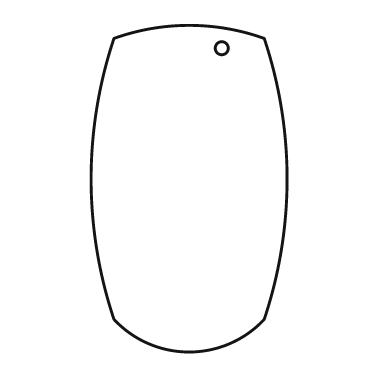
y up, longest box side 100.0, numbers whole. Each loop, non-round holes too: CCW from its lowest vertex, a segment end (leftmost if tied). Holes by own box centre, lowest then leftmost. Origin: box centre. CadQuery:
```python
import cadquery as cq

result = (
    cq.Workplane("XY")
    .moveTo(-23.0, -40.0)
    .threePointArc((0.0, -50.0), (23.0, -40.0))
    .threePointArc((30.0, 3.0), (23.0, 46.0))
    .threePointArc((0.0, 50.0), (-23.0, 46.0))
    .threePointArc((-30.0, 3.0), (-23.0, -40.0))
    .close()
    .moveTo(10.0, 43.0)
    .circle(2.0)
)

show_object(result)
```